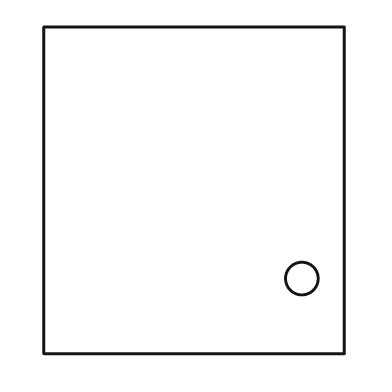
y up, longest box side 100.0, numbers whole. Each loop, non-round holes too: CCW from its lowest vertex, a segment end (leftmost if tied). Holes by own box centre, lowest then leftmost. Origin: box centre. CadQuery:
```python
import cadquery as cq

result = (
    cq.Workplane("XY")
    .moveTo(-46.0, -50.0)
    .lineTo(46.0, -50.0)
    .lineTo(46.0, 50.0)
    .lineTo(-46.0, 50.0)
    .close()
    .moveTo(33.0, -27.0)
    .circle(5.0)
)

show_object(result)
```